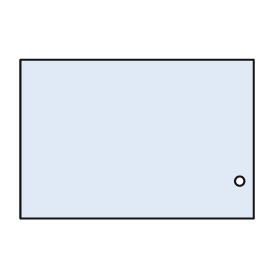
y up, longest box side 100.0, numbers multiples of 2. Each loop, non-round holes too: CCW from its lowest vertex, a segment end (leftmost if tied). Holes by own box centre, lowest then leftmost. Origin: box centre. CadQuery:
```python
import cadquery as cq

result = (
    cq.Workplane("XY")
    .moveTo(-50.0, -34.0)
    .lineTo(50.0, -34.0)
    .lineTo(50.0, 34.0)
    .lineTo(-50.0, 34.0)
    .close()
    .moveTo(44.0, -18.0)
    .circle(2.0)
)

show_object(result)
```